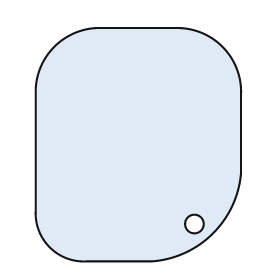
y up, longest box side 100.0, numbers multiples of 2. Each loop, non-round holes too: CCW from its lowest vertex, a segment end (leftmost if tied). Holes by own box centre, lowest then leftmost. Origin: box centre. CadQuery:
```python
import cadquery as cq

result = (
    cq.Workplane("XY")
    .moveTo(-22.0, -50.0)
    .lineTo(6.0, -50.0)
    .threePointArc((32.0, -38.0), (44.0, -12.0))
    .lineTo(44.0, 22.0)
    .threePointArc((36.0, 42.0), (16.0, 50.0))
    .lineTo(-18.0, 50.0)
    .threePointArc((-36.0, 42.0), (-44.0, 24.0))
    .lineTo(-44.0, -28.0)
    .threePointArc((-38.0, -44.0), (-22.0, -50.0))
    .close()
    .moveTo(24.0, -34.0)
    .circle(4.0)
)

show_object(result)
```